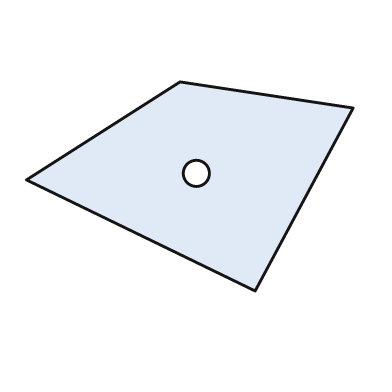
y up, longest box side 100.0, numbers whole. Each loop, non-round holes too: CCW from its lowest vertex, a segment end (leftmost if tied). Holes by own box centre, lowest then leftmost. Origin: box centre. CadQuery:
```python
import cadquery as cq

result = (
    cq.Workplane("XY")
    .moveTo(20.0, -32.0)
    .lineTo(50.0, 24.0)
    .lineTo(-3.0, 32.0)
    .lineTo(-50.0, 2.0)
    .close()
    .moveTo(2.0, 4.0)
    .circle(4.0)
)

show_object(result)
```